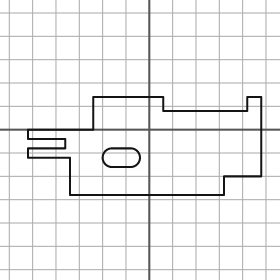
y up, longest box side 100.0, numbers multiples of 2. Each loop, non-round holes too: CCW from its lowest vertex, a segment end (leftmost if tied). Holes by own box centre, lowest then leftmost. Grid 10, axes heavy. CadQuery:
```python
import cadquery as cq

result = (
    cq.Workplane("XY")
    .moveTo(-34.0, -28.0)
    .lineTo(32.0, -28.0)
    .lineTo(32.0, -20.0)
    .lineTo(48.0, -20.0)
    .lineTo(48.0, 14.0)
    .lineTo(42.0, 14.0)
    .lineTo(42.0, 8.0)
    .lineTo(6.0, 8.0)
    .lineTo(6.0, 14.0)
    .lineTo(-24.0, 14.0)
    .lineTo(-24.0, 0.0)
    .lineTo(-52.0, 0.0)
    .lineTo(-52.0, -4.0)
    .lineTo(-36.0, -4.0)
    .lineTo(-36.0, -8.0)
    .lineTo(-52.0, -8.0)
    .lineTo(-52.0, -12.0)
    .lineTo(-34.0, -12.0)
    .close()
    .moveTo(-16.0, -16.0)
    .lineTo(-8.0, -16.0)
    .threePointArc((-4.0, -12.0), (-8.0, -8.0))
    .lineTo(-16.0, -8.0)
    .threePointArc((-20.0, -12.0), (-16.0, -16.0))
    .close()
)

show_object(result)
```